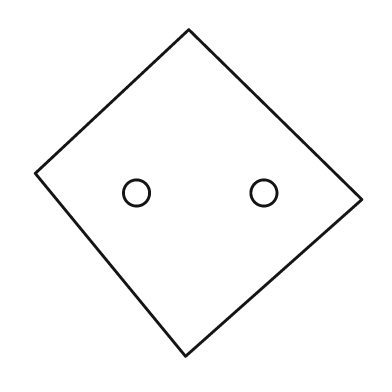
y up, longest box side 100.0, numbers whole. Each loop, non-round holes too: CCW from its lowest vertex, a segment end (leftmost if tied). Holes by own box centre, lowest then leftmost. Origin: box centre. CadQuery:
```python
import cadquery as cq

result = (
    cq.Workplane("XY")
    .moveTo(-4.0, -50.0)
    .lineTo(50.0, -2.0)
    .lineTo(-3.0, 50.0)
    .lineTo(-50.0, 6.0)
    .close()
    .moveTo(-19.0, 0.0)
    .circle(4.0)
    .moveTo(20.0, 0.0)
    .circle(4.0)
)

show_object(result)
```